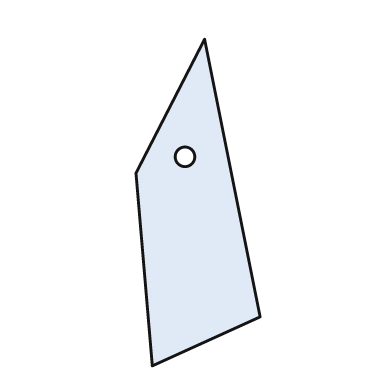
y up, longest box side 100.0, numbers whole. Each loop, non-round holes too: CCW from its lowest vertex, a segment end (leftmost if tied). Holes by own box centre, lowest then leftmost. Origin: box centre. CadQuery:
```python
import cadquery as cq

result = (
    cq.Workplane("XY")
    .moveTo(-14.0, -50.0)
    .lineTo(19.0, -35.0)
    .lineTo(2.0, 50.0)
    .lineTo(-19.0, 9.0)
    .close()
    .moveTo(-4.0, 14.0)
    .circle(3.0)
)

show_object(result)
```